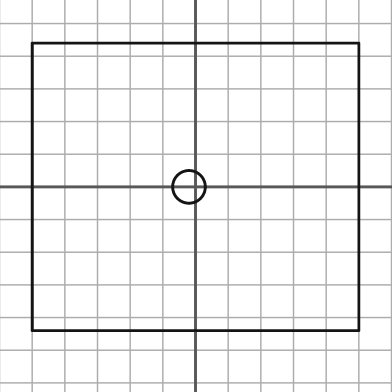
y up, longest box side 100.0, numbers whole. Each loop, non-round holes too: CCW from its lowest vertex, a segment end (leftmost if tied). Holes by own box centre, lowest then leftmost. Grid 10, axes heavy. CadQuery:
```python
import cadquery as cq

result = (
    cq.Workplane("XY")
    .moveTo(-50.0, -44.0)
    .lineTo(50.0, -44.0)
    .lineTo(50.0, 44.0)
    .lineTo(-50.0, 44.0)
    .close()
    .moveTo(-2.0, 0.0)
    .circle(5.0)
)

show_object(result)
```